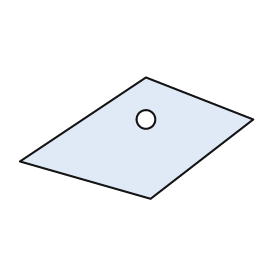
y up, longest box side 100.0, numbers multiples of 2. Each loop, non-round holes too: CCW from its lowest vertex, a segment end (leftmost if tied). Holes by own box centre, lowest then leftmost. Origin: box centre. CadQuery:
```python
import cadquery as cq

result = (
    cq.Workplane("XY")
    .moveTo(6.0, -26.0)
    .lineTo(50.0, 8.0)
    .lineTo(4.0, 26.0)
    .lineTo(-50.0, -10.0)
    .close()
    .moveTo(4.0, 8.0)
    .circle(4.0)
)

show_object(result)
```